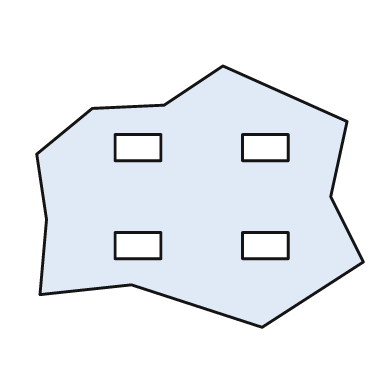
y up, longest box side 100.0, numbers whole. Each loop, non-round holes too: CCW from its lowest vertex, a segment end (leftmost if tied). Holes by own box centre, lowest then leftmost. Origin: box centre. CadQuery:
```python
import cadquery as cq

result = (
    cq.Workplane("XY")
    .moveTo(19.0, -40.0)
    .lineTo(50.0, -20.0)
    .lineTo(40.0, 0.0)
    .lineTo(45.0, 23.0)
    .lineTo(7.0, 40.0)
    .lineTo(-11.0, 28.0)
    .lineTo(-33.0, 27.0)
    .lineTo(-50.0, 13.0)
    .lineTo(-47.0, -7.0)
    .lineTo(-49.0, -30.0)
    .lineTo(-21.0, -27.0)
    .close()
    .moveTo(-26.0, -19.0)
    .lineTo(-12.0, -19.0)
    .lineTo(-12.0, -11.0)
    .lineTo(-26.0, -11.0)
    .close()
    .moveTo(13.0, -19.0)
    .lineTo(27.0, -19.0)
    .lineTo(27.0, -11.0)
    .lineTo(13.0, -11.0)
    .close()
    .moveTo(-26.0, 11.0)
    .lineTo(-12.0, 11.0)
    .lineTo(-12.0, 19.0)
    .lineTo(-26.0, 19.0)
    .close()
    .moveTo(13.0, 11.0)
    .lineTo(27.0, 11.0)
    .lineTo(27.0, 19.0)
    .lineTo(13.0, 19.0)
    .close()
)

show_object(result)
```